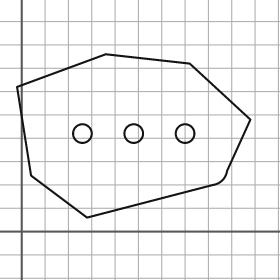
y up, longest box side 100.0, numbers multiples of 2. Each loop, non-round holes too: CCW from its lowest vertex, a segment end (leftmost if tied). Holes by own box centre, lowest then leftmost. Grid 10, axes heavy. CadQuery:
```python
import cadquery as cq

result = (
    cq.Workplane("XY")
    .moveTo(28.0, 6.0)
    .lineTo(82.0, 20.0)
    .threePointArc((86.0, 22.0), (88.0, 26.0))
    .lineTo(98.0, 48.0)
    .lineTo(72.0, 72.0)
    .lineTo(36.0, 76.0)
    .lineTo(-2.0, 62.0)
    .lineTo(4.0, 24.0)
    .close()
    .moveTo(26.0, 42.0)
    .circle(4.0)
    .moveTo(48.0, 42.0)
    .circle(4.0)
    .moveTo(70.0, 42.0)
    .circle(4.0)
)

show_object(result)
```